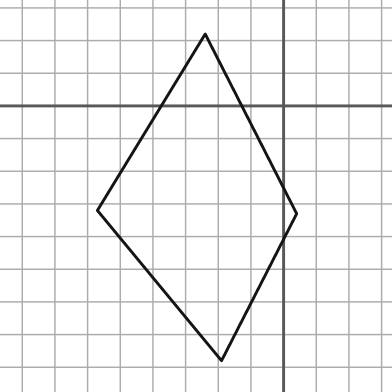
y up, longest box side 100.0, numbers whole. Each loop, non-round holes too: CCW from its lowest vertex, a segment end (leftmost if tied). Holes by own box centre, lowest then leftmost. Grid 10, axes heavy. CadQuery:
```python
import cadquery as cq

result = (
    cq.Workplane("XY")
    .moveTo(-19.0, -78.0)
    .lineTo(4.0, -33.0)
    .lineTo(-24.0, 22.0)
    .lineTo(-57.0, -32.0)
    .close()
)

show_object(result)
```